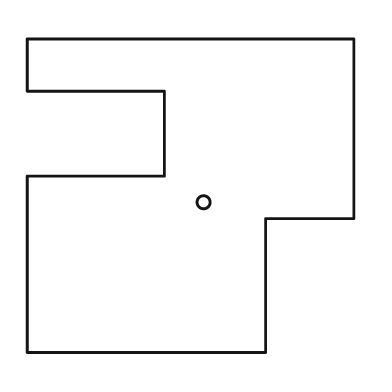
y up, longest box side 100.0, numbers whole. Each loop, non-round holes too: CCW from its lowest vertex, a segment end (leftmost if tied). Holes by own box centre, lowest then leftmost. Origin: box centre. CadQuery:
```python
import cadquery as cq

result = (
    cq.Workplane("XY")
    .moveTo(-50.0, -48.0)
    .lineTo(23.0, -48.0)
    .lineTo(23.0, -7.0)
    .lineTo(50.0, -7.0)
    .lineTo(50.0, 48.0)
    .lineTo(-50.0, 48.0)
    .lineTo(-50.0, 32.0)
    .lineTo(-8.0, 32.0)
    .lineTo(-8.0, 6.0)
    .lineTo(-50.0, 6.0)
    .close()
    .moveTo(4.0, -2.0)
    .circle(2.0)
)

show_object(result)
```